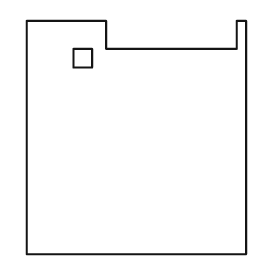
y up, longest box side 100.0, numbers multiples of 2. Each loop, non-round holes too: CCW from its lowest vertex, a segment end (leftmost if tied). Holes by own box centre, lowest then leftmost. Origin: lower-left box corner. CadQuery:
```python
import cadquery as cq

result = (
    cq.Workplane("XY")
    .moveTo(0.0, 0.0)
    .lineTo(94.0, 0.0)
    .lineTo(94.0, 100.0)
    .lineTo(90.0, 100.0)
    .lineTo(90.0, 88.0)
    .lineTo(34.0, 88.0)
    .lineTo(34.0, 100.0)
    .lineTo(0.0, 100.0)
    .close()
    .moveTo(20.0, 80.0)
    .lineTo(28.0, 80.0)
    .lineTo(28.0, 88.0)
    .lineTo(20.0, 88.0)
    .close()
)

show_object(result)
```